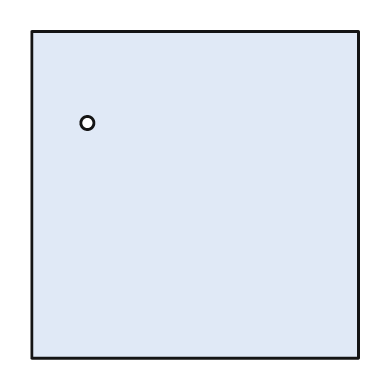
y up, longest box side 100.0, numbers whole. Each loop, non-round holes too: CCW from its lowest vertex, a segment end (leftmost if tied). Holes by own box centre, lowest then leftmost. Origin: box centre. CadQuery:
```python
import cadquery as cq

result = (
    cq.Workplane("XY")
    .moveTo(-50.0, -50.0)
    .lineTo(50.0, -50.0)
    .lineTo(50.0, 50.0)
    .lineTo(-50.0, 50.0)
    .close()
    .moveTo(-33.0, 22.0)
    .circle(2.0)
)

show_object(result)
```